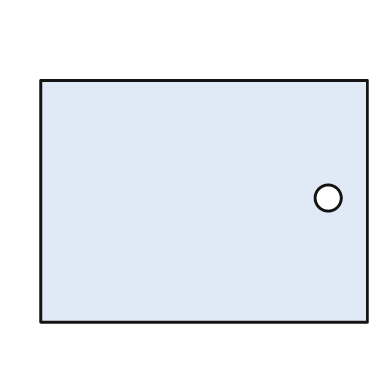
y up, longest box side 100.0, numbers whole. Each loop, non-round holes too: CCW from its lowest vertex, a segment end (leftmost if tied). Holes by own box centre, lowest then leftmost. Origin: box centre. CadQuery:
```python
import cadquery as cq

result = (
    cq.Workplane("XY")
    .moveTo(-50.0, -37.0)
    .lineTo(50.0, -37.0)
    .lineTo(50.0, 37.0)
    .lineTo(-50.0, 37.0)
    .close()
    .moveTo(38.0, 1.0)
    .circle(4.0)
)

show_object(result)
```